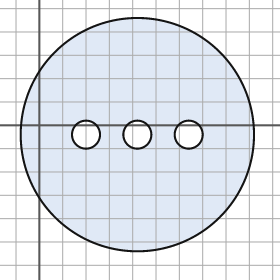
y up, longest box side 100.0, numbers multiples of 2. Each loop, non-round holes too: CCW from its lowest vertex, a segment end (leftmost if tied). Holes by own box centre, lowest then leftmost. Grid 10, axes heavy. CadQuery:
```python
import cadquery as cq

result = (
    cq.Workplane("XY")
    .moveTo(42.0, -4.0)
    .circle(50.0)
    .moveTo(20.0, -4.0)
    .circle(6.0)
    .moveTo(42.0, -4.0)
    .circle(6.0)
    .moveTo(64.0, -4.0)
    .circle(6.0)
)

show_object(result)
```